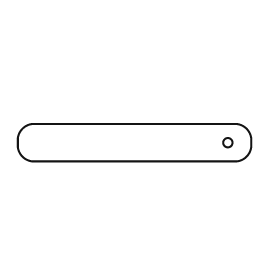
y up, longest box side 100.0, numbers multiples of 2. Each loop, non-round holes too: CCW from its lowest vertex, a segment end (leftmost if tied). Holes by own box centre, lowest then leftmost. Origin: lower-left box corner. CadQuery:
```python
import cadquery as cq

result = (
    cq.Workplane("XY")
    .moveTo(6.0, 0.0)
    .lineTo(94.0, 0.0)
    .threePointArc((98.0, 2.0), (100.0, 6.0))
    .lineTo(100.0, 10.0)
    .threePointArc((98.0, 14.0), (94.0, 16.0))
    .lineTo(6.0, 16.0)
    .threePointArc((2.0, 14.0), (0.0, 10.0))
    .lineTo(0.0, 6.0)
    .threePointArc((2.0, 2.0), (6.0, 0.0))
    .close()
    .moveTo(90.0, 8.0)
    .circle(2.0)
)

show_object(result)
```